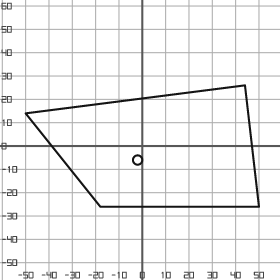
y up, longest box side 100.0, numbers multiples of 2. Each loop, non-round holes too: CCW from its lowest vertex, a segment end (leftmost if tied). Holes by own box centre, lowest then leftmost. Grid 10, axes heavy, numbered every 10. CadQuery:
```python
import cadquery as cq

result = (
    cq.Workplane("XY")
    .moveTo(-18.0, -26.0)
    .lineTo(50.0, -26.0)
    .lineTo(44.0, 26.0)
    .lineTo(-50.0, 14.0)
    .close()
    .moveTo(-2.0, -6.0)
    .circle(2.0)
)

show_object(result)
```